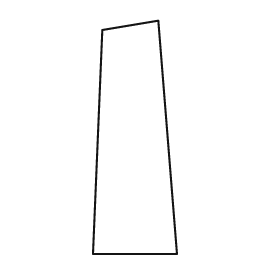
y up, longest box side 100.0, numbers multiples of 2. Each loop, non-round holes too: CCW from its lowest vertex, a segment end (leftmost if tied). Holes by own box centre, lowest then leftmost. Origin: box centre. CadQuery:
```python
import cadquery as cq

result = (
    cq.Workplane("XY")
    .moveTo(-18.0, -50.0)
    .lineTo(18.0, -50.0)
    .lineTo(10.0, 50.0)
    .lineTo(-14.0, 46.0)
    .close()
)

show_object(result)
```